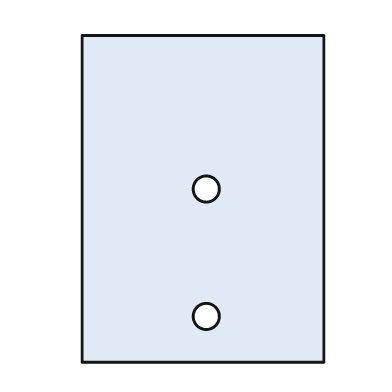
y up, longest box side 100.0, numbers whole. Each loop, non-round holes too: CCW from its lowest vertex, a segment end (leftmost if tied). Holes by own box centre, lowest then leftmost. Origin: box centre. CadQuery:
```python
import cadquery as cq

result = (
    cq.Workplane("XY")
    .moveTo(-37.0, -50.0)
    .lineTo(37.0, -50.0)
    .lineTo(37.0, 50.0)
    .lineTo(-37.0, 50.0)
    .close()
    .moveTo(1.0, -36.0)
    .circle(4.0)
    .moveTo(1.0, 3.0)
    .circle(4.0)
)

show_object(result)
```